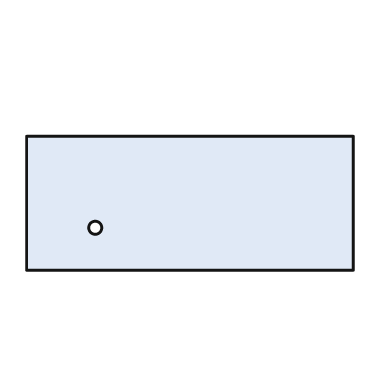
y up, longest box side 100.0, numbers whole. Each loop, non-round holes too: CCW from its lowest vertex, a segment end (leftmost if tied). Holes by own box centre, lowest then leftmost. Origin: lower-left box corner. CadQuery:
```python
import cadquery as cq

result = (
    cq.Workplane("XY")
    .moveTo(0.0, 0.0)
    .lineTo(100.0, 0.0)
    .lineTo(100.0, 41.0)
    .lineTo(0.0, 41.0)
    .close()
    .moveTo(21.0, 13.0)
    .circle(2.0)
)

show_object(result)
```